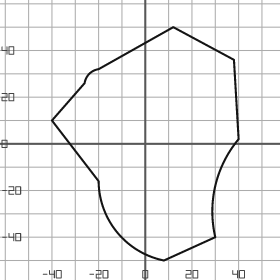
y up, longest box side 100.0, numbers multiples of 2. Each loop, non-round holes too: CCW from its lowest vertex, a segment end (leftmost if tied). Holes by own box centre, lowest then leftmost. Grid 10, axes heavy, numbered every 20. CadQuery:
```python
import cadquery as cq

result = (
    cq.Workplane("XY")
    .moveTo(8.0, -50.0)
    .lineTo(30.0, -40.0)
    .threePointArc((30.0, -18.0), (40.0, 2.0))
    .lineTo(38.0, 36.0)
    .lineTo(12.0, 50.0)
    .lineTo(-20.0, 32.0)
    .threePointArc((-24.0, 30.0), (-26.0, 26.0))
    .lineTo(-40.0, 10.0)
    .lineTo(-20.0, -16.0)
    .threePointArc((-12.0, -38.0), (8.0, -50.0))
    .close()
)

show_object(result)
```